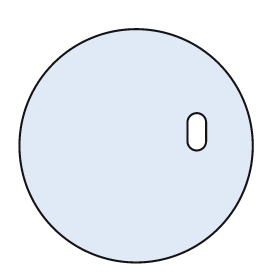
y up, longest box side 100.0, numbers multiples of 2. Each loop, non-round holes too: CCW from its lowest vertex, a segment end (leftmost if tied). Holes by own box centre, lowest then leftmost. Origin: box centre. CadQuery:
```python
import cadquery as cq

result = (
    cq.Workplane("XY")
    .moveTo(0.0, 0.0)
    .circle(50.0)
    .moveTo(22.0, 2.0)
    .threePointArc((26.0, -2.0), (30.0, 2.0))
    .lineTo(30.0, 10.0)
    .threePointArc((26.0, 14.0), (22.0, 10.0))
    .close()
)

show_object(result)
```